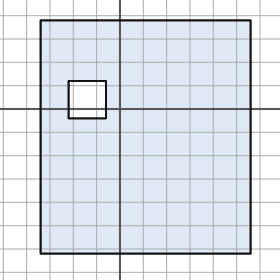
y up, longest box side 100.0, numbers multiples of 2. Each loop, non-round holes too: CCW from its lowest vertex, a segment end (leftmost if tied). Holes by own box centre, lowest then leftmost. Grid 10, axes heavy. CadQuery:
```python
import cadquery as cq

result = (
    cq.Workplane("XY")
    .moveTo(-34.0, -62.0)
    .lineTo(56.0, -62.0)
    .lineTo(56.0, 38.0)
    .lineTo(-34.0, 38.0)
    .close()
    .moveTo(-22.0, -4.0)
    .lineTo(-6.0, -4.0)
    .lineTo(-6.0, 12.0)
    .lineTo(-22.0, 12.0)
    .close()
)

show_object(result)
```